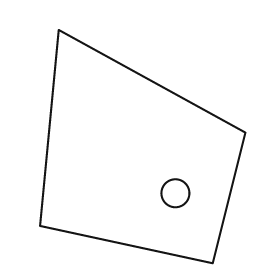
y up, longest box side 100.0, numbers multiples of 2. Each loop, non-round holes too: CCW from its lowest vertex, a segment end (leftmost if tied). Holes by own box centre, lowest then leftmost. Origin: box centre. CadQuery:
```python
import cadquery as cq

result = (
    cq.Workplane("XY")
    .moveTo(30.0, -50.0)
    .lineTo(44.0, 6.0)
    .lineTo(-36.0, 50.0)
    .lineTo(-44.0, -34.0)
    .close()
    .moveTo(14.0, -20.0)
    .circle(6.0)
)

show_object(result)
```